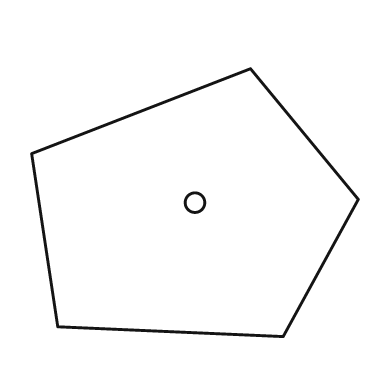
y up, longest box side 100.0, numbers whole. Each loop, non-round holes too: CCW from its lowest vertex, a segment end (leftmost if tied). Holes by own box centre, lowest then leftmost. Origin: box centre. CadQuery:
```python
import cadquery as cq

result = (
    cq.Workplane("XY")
    .moveTo(27.0, -41.0)
    .lineTo(50.0, 1.0)
    .lineTo(17.0, 41.0)
    .lineTo(-50.0, 15.0)
    .lineTo(-42.0, -38.0)
    .close()
    .moveTo(0.0, 0.0)
    .circle(3.0)
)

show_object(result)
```